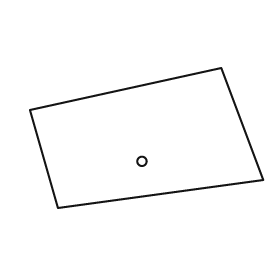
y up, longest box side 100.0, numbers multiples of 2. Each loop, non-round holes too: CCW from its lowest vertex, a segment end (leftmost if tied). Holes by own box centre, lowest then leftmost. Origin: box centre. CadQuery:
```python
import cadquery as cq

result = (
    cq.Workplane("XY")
    .moveTo(-38.0, -30.0)
    .lineTo(50.0, -18.0)
    .lineTo(32.0, 30.0)
    .lineTo(-50.0, 12.0)
    .close()
    .moveTo(-2.0, -10.0)
    .circle(2.0)
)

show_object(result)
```